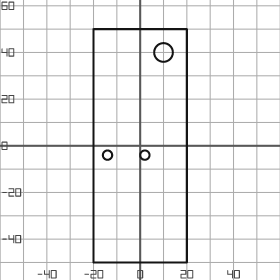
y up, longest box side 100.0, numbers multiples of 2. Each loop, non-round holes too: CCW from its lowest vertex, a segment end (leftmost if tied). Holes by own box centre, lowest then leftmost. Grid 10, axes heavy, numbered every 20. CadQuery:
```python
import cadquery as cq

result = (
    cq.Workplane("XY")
    .moveTo(-20.0, -50.0)
    .lineTo(20.0, -50.0)
    .lineTo(20.0, 50.0)
    .lineTo(-20.0, 50.0)
    .close()
    .moveTo(-14.0, -4.0)
    .circle(2.0)
    .moveTo(2.0, -4.0)
    .circle(2.0)
    .moveTo(10.0, 40.0)
    .circle(4.0)
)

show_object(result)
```